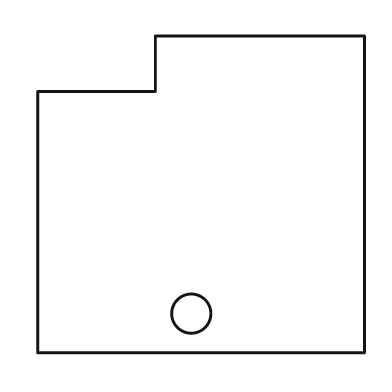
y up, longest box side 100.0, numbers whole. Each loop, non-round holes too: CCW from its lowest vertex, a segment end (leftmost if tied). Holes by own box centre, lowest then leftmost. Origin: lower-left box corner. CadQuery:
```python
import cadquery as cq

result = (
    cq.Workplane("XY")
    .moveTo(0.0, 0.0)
    .lineTo(100.0, 0.0)
    .lineTo(100.0, 97.0)
    .lineTo(36.0, 97.0)
    .lineTo(36.0, 80.0)
    .lineTo(0.0, 80.0)
    .close()
    .moveTo(47.0, 12.0)
    .circle(6.0)
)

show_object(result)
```